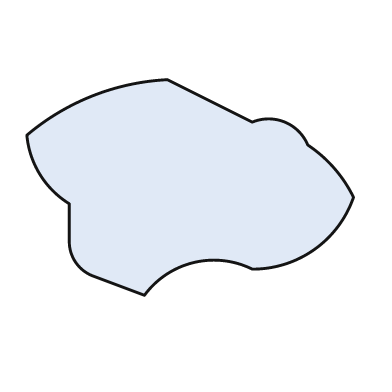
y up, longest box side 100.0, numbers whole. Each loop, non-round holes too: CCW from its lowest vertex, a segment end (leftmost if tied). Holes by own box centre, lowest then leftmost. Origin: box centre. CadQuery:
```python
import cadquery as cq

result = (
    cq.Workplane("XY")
    .moveTo(-14.0, -33.0)
    .threePointArc((1.0, -23.0), (19.0, -25.0))
    .threePointArc((38.0, -19.0), (50.0, -3.0))
    .threePointArc((44.0, 6.0), (36.0, 13.0))
    .threePointArc((29.0, 20.0), (19.0, 20.0))
    .lineTo(-7.0, 33.0)
    .threePointArc((-30.0, 28.0), (-50.0, 16.0))
    .threePointArc((-46.0, 4.0), (-37.0, -5.0))
    .lineTo(-37.0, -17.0)
    .threePointArc((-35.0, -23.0), (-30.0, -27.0))
    .close()
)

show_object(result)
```